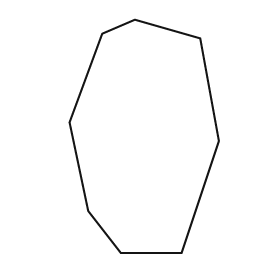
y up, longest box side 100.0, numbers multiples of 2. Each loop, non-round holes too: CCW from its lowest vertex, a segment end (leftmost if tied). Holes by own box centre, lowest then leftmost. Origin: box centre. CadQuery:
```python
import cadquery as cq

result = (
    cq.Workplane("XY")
    .moveTo(-10.0, -50.0)
    .lineTo(16.0, -50.0)
    .lineTo(32.0, -2.0)
    .lineTo(24.0, 42.0)
    .lineTo(-4.0, 50.0)
    .lineTo(-18.0, 44.0)
    .lineTo(-32.0, 6.0)
    .lineTo(-24.0, -32.0)
    .close()
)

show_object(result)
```